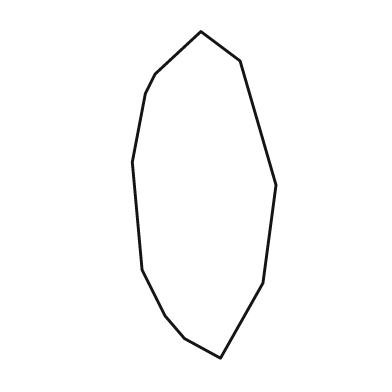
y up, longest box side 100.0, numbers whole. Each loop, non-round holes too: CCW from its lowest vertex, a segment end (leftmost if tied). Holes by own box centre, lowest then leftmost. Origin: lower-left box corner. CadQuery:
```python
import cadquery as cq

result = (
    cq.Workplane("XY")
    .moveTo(27.0, 0.0)
    .lineTo(40.0, 23.0)
    .lineTo(44.0, 53.0)
    .lineTo(33.0, 91.0)
    .lineTo(21.0, 100.0)
    .lineTo(7.0, 87.0)
    .lineTo(4.0, 81.0)
    .lineTo(0.0, 60.0)
    .lineTo(3.0, 27.0)
    .lineTo(10.0, 13.0)
    .lineTo(16.0, 6.0)
    .close()
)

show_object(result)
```